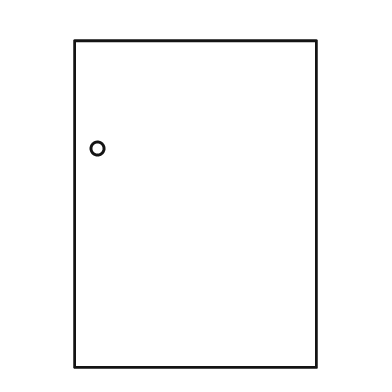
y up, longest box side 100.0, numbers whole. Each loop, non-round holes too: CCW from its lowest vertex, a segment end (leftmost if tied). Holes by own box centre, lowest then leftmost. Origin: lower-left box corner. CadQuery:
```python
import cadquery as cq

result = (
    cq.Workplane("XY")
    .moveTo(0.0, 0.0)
    .lineTo(74.0, 0.0)
    .lineTo(74.0, 100.0)
    .lineTo(0.0, 100.0)
    .close()
    .moveTo(7.0, 67.0)
    .circle(2.0)
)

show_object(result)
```